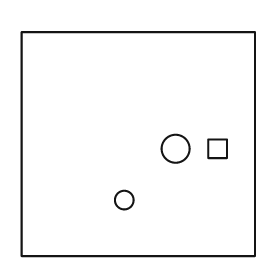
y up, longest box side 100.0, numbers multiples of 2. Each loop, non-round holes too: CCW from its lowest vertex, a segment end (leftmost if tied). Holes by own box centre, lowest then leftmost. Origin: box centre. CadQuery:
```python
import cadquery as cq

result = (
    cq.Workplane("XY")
    .moveTo(-50.0, -48.0)
    .lineTo(50.0, -48.0)
    .lineTo(50.0, 48.0)
    .lineTo(-50.0, 48.0)
    .close()
    .moveTo(-6.0, -24.0)
    .circle(4.0)
    .moveTo(16.0, -2.0)
    .circle(6.0)
    .moveTo(30.0, -6.0)
    .lineTo(38.0, -6.0)
    .lineTo(38.0, 2.0)
    .lineTo(30.0, 2.0)
    .close()
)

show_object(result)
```